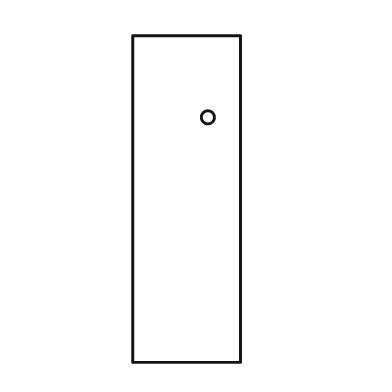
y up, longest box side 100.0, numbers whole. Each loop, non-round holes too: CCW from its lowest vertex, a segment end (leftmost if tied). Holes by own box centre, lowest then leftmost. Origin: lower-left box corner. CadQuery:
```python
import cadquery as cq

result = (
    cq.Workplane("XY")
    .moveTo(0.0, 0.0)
    .lineTo(33.0, 0.0)
    .lineTo(33.0, 100.0)
    .lineTo(0.0, 100.0)
    .close()
    .moveTo(23.0, 75.0)
    .circle(2.0)
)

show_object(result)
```